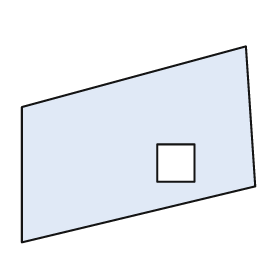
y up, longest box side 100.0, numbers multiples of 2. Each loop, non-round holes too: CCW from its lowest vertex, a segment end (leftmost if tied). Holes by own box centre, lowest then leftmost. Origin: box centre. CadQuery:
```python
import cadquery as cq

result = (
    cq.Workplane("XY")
    .moveTo(-50.0, -42.0)
    .lineTo(50.0, -18.0)
    .lineTo(46.0, 42.0)
    .lineTo(-50.0, 16.0)
    .close()
    .moveTo(8.0, -16.0)
    .lineTo(24.0, -16.0)
    .lineTo(24.0, 0.0)
    .lineTo(8.0, 0.0)
    .close()
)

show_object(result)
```